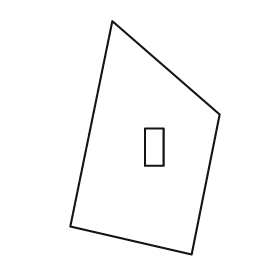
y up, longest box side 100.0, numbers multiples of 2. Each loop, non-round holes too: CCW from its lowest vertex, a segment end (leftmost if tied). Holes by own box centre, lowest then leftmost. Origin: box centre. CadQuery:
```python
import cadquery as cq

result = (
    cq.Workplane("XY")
    .moveTo(20.0, -50.0)
    .lineTo(32.0, 10.0)
    .lineTo(-14.0, 50.0)
    .lineTo(-32.0, -38.0)
    .close()
    .moveTo(0.0, -12.0)
    .lineTo(8.0, -12.0)
    .lineTo(8.0, 4.0)
    .lineTo(0.0, 4.0)
    .close()
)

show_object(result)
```